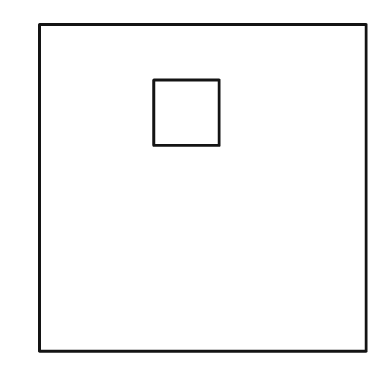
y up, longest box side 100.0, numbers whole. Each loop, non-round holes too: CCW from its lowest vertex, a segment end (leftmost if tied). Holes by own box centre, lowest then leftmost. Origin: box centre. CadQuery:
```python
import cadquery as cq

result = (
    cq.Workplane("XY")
    .moveTo(-50.0, -50.0)
    .lineTo(50.0, -50.0)
    .lineTo(50.0, 50.0)
    .lineTo(-50.0, 50.0)
    .close()
    .moveTo(-15.0, 13.0)
    .lineTo(5.0, 13.0)
    .lineTo(5.0, 33.0)
    .lineTo(-15.0, 33.0)
    .close()
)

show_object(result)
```